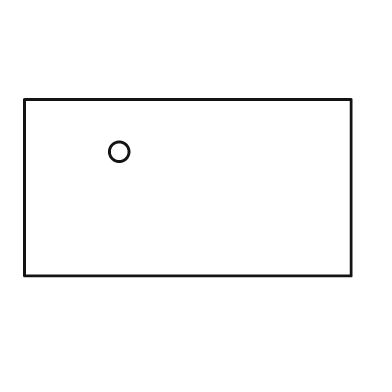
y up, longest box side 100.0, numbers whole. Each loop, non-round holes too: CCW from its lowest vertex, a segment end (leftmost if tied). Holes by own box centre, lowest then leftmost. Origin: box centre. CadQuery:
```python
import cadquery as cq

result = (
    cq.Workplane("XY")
    .moveTo(-50.0, -27.0)
    .lineTo(50.0, -27.0)
    .lineTo(50.0, 27.0)
    .lineTo(-50.0, 27.0)
    .close()
    .moveTo(-21.0, 11.0)
    .circle(3.0)
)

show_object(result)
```